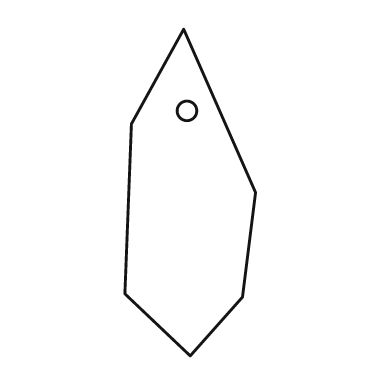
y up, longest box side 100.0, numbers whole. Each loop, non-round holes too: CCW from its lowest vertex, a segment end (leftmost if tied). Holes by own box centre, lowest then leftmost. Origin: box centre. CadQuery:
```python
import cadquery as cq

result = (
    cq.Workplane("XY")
    .moveTo(0.0, -50.0)
    .lineTo(16.0, -32.0)
    .lineTo(20.0, 0.0)
    .lineTo(-2.0, 50.0)
    .lineTo(-18.0, 21.0)
    .lineTo(-20.0, -31.0)
    .close()
    .moveTo(-1.0, 25.0)
    .circle(3.0)
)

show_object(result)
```